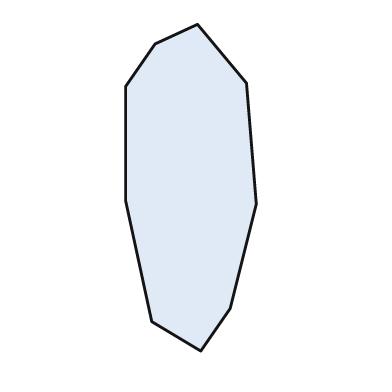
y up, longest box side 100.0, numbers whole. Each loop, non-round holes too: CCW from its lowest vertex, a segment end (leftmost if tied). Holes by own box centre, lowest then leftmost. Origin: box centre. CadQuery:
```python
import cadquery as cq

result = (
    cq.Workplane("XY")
    .moveTo(3.0, -50.0)
    .lineTo(12.0, -37.0)
    .lineTo(20.0, -5.0)
    .lineTo(17.0, 32.0)
    .lineTo(2.0, 50.0)
    .lineTo(-11.0, 44.0)
    .lineTo(-20.0, 31.0)
    .lineTo(-20.0, -4.0)
    .lineTo(-12.0, -41.0)
    .close()
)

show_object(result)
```